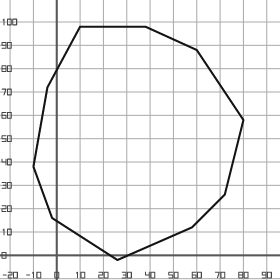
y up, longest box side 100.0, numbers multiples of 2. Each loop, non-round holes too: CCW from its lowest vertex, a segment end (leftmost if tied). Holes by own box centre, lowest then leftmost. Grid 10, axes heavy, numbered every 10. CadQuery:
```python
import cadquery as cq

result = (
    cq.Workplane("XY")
    .moveTo(26.0, -2.0)
    .lineTo(58.0, 12.0)
    .lineTo(72.0, 26.0)
    .lineTo(80.0, 58.0)
    .lineTo(60.0, 88.0)
    .lineTo(38.0, 98.0)
    .lineTo(10.0, 98.0)
    .lineTo(-4.0, 72.0)
    .lineTo(-10.0, 38.0)
    .lineTo(-2.0, 16.0)
    .close()
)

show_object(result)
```